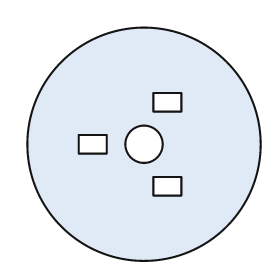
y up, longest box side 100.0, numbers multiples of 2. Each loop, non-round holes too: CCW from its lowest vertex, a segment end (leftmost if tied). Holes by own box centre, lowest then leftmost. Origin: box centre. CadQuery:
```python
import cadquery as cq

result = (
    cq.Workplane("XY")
    .moveTo(0.0, 0.0)
    .circle(50.0)
    .moveTo(4.0, -22.0)
    .lineTo(16.0, -22.0)
    .lineTo(16.0, -14.0)
    .lineTo(4.0, -14.0)
    .close()
    .moveTo(-28.0, -4.0)
    .lineTo(-16.0, -4.0)
    .lineTo(-16.0, 4.0)
    .lineTo(-28.0, 4.0)
    .close()
    .moveTo(0.0, 0.0)
    .circle(8.0)
    .moveTo(4.0, 14.0)
    .lineTo(16.0, 14.0)
    .lineTo(16.0, 22.0)
    .lineTo(4.0, 22.0)
    .close()
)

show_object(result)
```